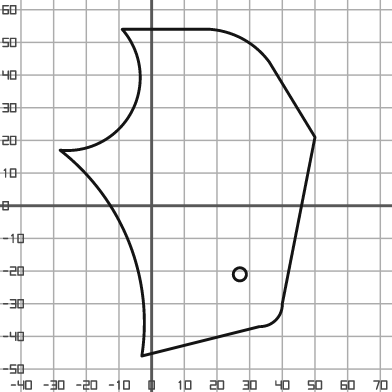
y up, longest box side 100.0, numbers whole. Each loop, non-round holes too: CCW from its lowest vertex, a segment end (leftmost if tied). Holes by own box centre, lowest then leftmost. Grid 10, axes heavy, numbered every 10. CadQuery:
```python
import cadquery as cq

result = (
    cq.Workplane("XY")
    .moveTo(-3.0, -46.0)
    .lineTo(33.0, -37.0)
    .threePointArc((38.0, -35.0), (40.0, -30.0))
    .lineTo(50.0, 21.0)
    .lineTo(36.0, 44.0)
    .threePointArc((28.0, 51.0), (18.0, 54.0))
    .lineTo(-9.0, 54.0)
    .threePointArc((-6.0, 29.0), (-28.0, 17.0))
    .threePointArc((-7.0, -11.0), (-3.0, -46.0))
    .close()
    .moveTo(27.0, -21.0)
    .circle(2.0)
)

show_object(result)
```